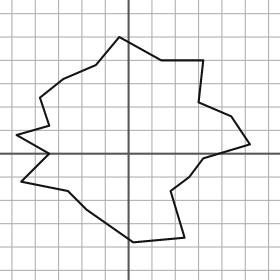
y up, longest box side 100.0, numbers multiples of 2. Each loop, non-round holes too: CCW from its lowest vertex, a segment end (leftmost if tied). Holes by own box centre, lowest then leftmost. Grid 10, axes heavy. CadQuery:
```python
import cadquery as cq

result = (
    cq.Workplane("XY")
    .moveTo(2.0, -38.0)
    .lineTo(24.0, -36.0)
    .lineTo(18.0, -16.0)
    .lineTo(26.0, -10.0)
    .lineTo(32.0, -2.0)
    .lineTo(52.0, 4.0)
    .lineTo(44.0, 16.0)
    .lineTo(30.0, 22.0)
    .lineTo(32.0, 40.0)
    .lineTo(14.0, 40.0)
    .lineTo(-4.0, 50.0)
    .lineTo(-14.0, 38.0)
    .lineTo(-28.0, 32.0)
    .lineTo(-38.0, 24.0)
    .lineTo(-34.0, 12.0)
    .lineTo(-48.0, 8.0)
    .lineTo(-34.0, 0.0)
    .lineTo(-46.0, -12.0)
    .lineTo(-26.0, -16.0)
    .lineTo(-18.0, -24.0)
    .close()
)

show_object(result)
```